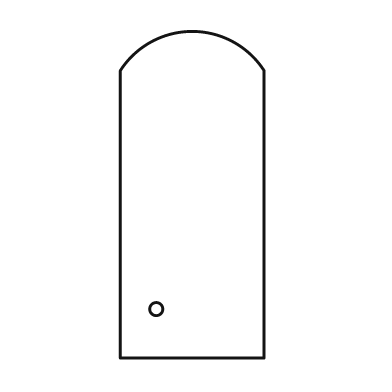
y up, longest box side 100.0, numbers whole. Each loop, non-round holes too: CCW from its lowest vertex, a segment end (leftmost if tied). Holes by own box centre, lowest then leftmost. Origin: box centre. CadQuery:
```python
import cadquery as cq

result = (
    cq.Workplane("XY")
    .moveTo(-22.0, -50.0)
    .lineTo(22.0, -50.0)
    .lineTo(22.0, 38.0)
    .threePointArc((0.0, 50.0), (-22.0, 38.0))
    .close()
    .moveTo(-11.0, -35.0)
    .circle(2.0)
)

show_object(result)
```